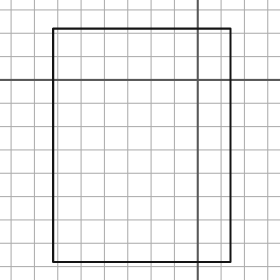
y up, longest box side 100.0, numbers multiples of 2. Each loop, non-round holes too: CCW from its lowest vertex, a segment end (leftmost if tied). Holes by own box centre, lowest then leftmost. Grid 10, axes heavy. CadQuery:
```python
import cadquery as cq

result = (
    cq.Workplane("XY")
    .moveTo(-62.0, -78.0)
    .lineTo(14.0, -78.0)
    .lineTo(14.0, 22.0)
    .lineTo(-62.0, 22.0)
    .close()
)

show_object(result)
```